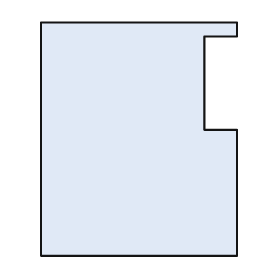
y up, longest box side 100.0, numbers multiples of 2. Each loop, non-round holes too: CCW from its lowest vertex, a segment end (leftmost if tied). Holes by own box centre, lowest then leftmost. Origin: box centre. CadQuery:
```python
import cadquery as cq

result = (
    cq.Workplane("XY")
    .moveTo(-42.0, -50.0)
    .lineTo(42.0, -50.0)
    .lineTo(42.0, 4.0)
    .lineTo(28.0, 4.0)
    .lineTo(28.0, 44.0)
    .lineTo(42.0, 44.0)
    .lineTo(42.0, 50.0)
    .lineTo(-42.0, 50.0)
    .close()
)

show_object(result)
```